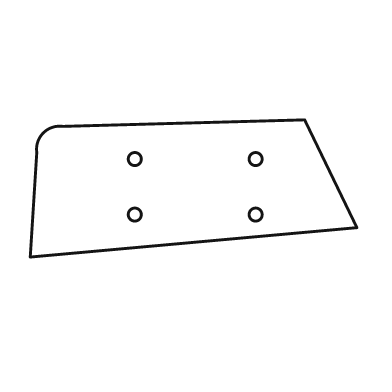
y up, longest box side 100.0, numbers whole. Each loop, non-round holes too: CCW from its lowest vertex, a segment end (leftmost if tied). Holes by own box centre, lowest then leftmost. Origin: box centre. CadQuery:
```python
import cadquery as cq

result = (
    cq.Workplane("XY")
    .moveTo(-50.0, -21.0)
    .lineTo(50.0, -12.0)
    .lineTo(34.0, 21.0)
    .lineTo(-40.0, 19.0)
    .threePointArc((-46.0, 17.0), (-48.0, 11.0))
    .close()
    .moveTo(-18.0, -8.0)
    .circle(2.0)
    .moveTo(19.0, -8.0)
    .circle(2.0)
    .moveTo(-18.0, 9.0)
    .circle(2.0)
    .moveTo(19.0, 9.0)
    .circle(2.0)
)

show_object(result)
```